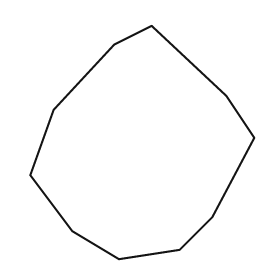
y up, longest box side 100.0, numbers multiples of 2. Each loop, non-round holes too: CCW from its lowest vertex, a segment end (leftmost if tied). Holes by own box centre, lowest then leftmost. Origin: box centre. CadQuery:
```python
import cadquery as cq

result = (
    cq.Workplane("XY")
    .moveTo(-10.0, -50.0)
    .lineTo(16.0, -46.0)
    .lineTo(30.0, -32.0)
    .lineTo(48.0, 2.0)
    .lineTo(36.0, 20.0)
    .lineTo(4.0, 50.0)
    .lineTo(-12.0, 42.0)
    .lineTo(-38.0, 14.0)
    .lineTo(-48.0, -14.0)
    .lineTo(-30.0, -38.0)
    .close()
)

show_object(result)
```